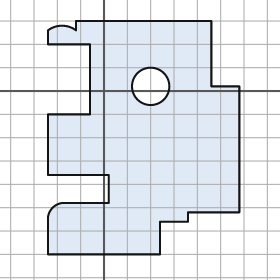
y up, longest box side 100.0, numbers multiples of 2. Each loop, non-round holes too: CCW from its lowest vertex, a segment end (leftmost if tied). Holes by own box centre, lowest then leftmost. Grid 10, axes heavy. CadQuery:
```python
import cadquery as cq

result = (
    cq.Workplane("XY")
    .moveTo(-24.0, -70.0)
    .lineTo(24.0, -70.0)
    .lineTo(24.0, -56.0)
    .lineTo(36.0, -56.0)
    .lineTo(36.0, -52.0)
    .lineTo(58.0, -52.0)
    .lineTo(58.0, 2.0)
    .lineTo(46.0, 2.0)
    .lineTo(46.0, 30.0)
    .lineTo(-12.0, 30.0)
    .lineTo(-12.0, 26.0)
    .threePointArc((-18.0, 28.0), (-24.0, 26.0))
    .lineTo(-24.0, 20.0)
    .lineTo(-6.0, 20.0)
    .lineTo(-6.0, -10.0)
    .lineTo(-24.0, -10.0)
    .lineTo(-24.0, -36.0)
    .lineTo(2.0, -36.0)
    .lineTo(2.0, -48.0)
    .lineTo(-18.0, -48.0)
    .threePointArc((-22.0, -50.0), (-24.0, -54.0))
    .close()
    .moveTo(20.0, 2.0)
    .circle(8.0)
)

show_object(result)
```